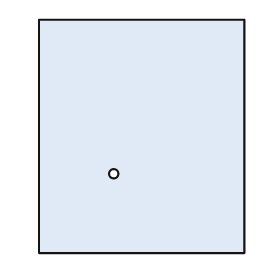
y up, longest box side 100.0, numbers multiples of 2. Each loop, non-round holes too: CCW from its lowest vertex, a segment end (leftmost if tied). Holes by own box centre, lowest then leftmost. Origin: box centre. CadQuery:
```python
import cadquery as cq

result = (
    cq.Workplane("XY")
    .moveTo(-44.0, -50.0)
    .lineTo(44.0, -50.0)
    .lineTo(44.0, 50.0)
    .lineTo(-44.0, 50.0)
    .close()
    .moveTo(-12.0, -16.0)
    .circle(2.0)
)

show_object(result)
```